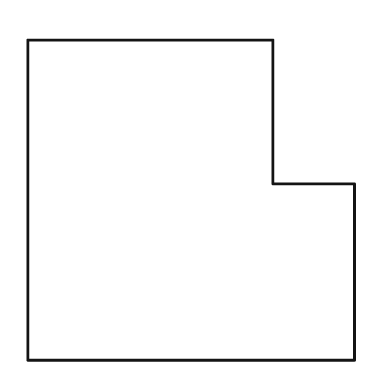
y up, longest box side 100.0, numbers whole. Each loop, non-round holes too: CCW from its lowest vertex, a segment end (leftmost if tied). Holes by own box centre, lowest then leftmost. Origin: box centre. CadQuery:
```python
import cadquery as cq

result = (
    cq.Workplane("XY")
    .moveTo(-50.0, -49.0)
    .lineTo(50.0, -49.0)
    .lineTo(50.0, 5.0)
    .lineTo(25.0, 5.0)
    .lineTo(25.0, 49.0)
    .lineTo(-50.0, 49.0)
    .close()
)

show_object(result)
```